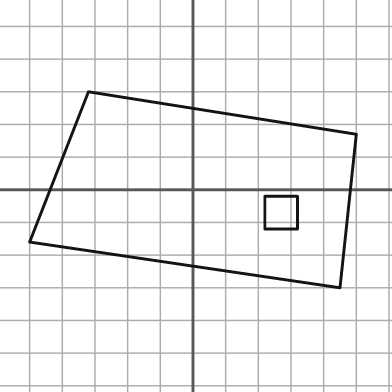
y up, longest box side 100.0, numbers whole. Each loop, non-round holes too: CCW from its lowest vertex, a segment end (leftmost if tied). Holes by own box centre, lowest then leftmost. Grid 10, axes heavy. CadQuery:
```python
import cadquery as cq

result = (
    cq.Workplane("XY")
    .moveTo(45.0, -30.0)
    .lineTo(50.0, 17.0)
    .lineTo(-32.0, 30.0)
    .lineTo(-50.0, -16.0)
    .close()
    .moveTo(22.0, -12.0)
    .lineTo(32.0, -12.0)
    .lineTo(32.0, -2.0)
    .lineTo(22.0, -2.0)
    .close()
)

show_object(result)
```